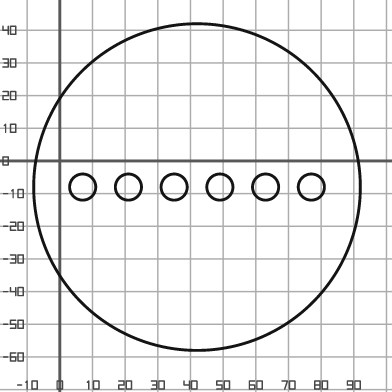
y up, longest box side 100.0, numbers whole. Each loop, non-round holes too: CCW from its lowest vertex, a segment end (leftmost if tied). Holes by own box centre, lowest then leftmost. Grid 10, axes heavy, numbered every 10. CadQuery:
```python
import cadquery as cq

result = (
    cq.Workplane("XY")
    .moveTo(42.0, -8.0)
    .circle(50.0)
    .moveTo(7.0, -8.0)
    .circle(4.0)
    .moveTo(21.0, -8.0)
    .circle(4.0)
    .moveTo(35.0, -8.0)
    .circle(4.0)
    .moveTo(49.0, -8.0)
    .circle(4.0)
    .moveTo(63.0, -8.0)
    .circle(4.0)
    .moveTo(77.0, -8.0)
    .circle(4.0)
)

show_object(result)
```